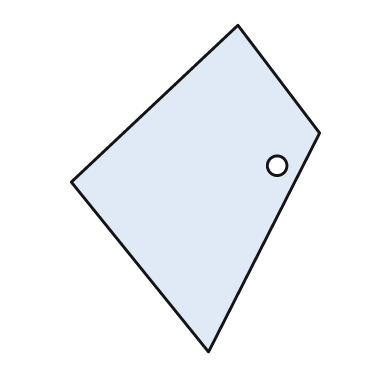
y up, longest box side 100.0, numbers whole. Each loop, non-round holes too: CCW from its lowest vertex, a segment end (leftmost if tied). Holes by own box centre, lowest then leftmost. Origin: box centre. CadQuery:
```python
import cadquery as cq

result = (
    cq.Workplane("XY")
    .moveTo(4.0, -50.0)
    .lineTo(38.0, 17.0)
    .lineTo(13.0, 50.0)
    .lineTo(-38.0, 2.0)
    .close()
    .moveTo(25.0, 7.0)
    .circle(3.0)
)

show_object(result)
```